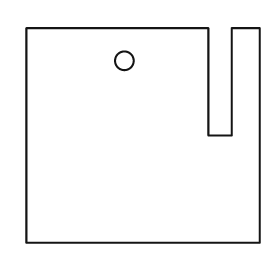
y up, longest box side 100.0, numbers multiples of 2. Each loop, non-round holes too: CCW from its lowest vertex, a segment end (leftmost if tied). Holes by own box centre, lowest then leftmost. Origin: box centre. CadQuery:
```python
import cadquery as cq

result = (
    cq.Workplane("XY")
    .moveTo(-50.0, -46.0)
    .lineTo(50.0, -46.0)
    .lineTo(50.0, 46.0)
    .lineTo(38.0, 46.0)
    .lineTo(38.0, 0.0)
    .lineTo(28.0, 0.0)
    .lineTo(28.0, 46.0)
    .lineTo(-50.0, 46.0)
    .close()
    .moveTo(-8.0, 32.0)
    .circle(4.0)
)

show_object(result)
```